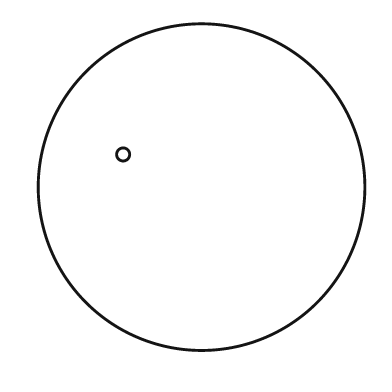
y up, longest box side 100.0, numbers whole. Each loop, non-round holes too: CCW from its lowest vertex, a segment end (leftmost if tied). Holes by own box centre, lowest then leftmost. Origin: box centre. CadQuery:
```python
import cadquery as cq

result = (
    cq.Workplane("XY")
    .moveTo(0.0, 0.0)
    .circle(50.0)
    .moveTo(-24.0, 10.0)
    .circle(2.0)
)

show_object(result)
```